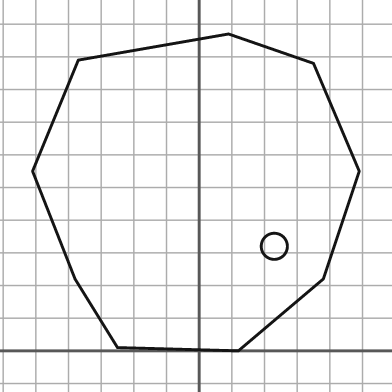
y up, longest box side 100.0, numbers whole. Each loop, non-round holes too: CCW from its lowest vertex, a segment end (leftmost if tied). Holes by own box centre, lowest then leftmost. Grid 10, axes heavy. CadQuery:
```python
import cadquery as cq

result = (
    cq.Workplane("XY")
    .moveTo(12.0, 0.0)
    .lineTo(38.0, 22.0)
    .lineTo(49.0, 55.0)
    .lineTo(35.0, 88.0)
    .lineTo(9.0, 97.0)
    .lineTo(-37.0, 89.0)
    .lineTo(-51.0, 55.0)
    .lineTo(-38.0, 22.0)
    .lineTo(-25.0, 1.0)
    .close()
    .moveTo(23.0, 32.0)
    .circle(4.0)
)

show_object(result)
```